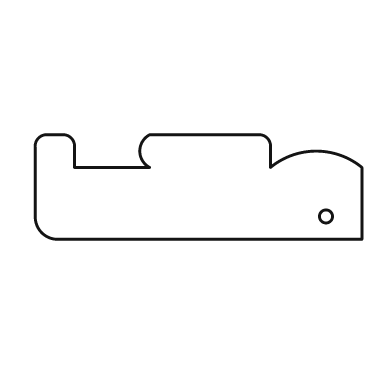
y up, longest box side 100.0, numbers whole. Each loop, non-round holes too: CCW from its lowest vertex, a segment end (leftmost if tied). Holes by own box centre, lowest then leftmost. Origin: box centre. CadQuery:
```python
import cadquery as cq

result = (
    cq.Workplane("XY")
    .moveTo(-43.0, -16.0)
    .lineTo(50.0, -16.0)
    .lineTo(50.0, 6.0)
    .threePointArc((36.0, 11.0), (22.0, 6.0))
    .lineTo(22.0, 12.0)
    .threePointArc((21.0, 15.0), (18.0, 16.0))
    .lineTo(-15.0, 16.0)
    .threePointArc((-18.0, 11.0), (-15.0, 6.0))
    .lineTo(-38.0, 6.0)
    .lineTo(-38.0, 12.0)
    .threePointArc((-39.0, 15.0), (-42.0, 16.0))
    .lineTo(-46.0, 16.0)
    .threePointArc((-49.0, 15.0), (-50.0, 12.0))
    .lineTo(-50.0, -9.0)
    .threePointArc((-48.0, -14.0), (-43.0, -16.0))
    .close()
    .moveTo(39.0, -9.0)
    .circle(2.0)
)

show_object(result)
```